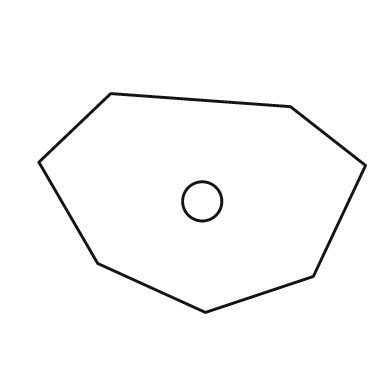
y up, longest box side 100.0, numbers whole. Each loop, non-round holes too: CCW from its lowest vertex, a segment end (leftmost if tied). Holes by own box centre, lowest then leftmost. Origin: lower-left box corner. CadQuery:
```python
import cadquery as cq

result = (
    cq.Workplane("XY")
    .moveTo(51.0, 0.0)
    .lineTo(84.0, 11.0)
    .lineTo(100.0, 45.0)
    .lineTo(77.0, 63.0)
    .lineTo(22.0, 67.0)
    .lineTo(0.0, 46.0)
    .lineTo(18.0, 15.0)
    .close()
    .moveTo(50.0, 34.0)
    .circle(6.0)
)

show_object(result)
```